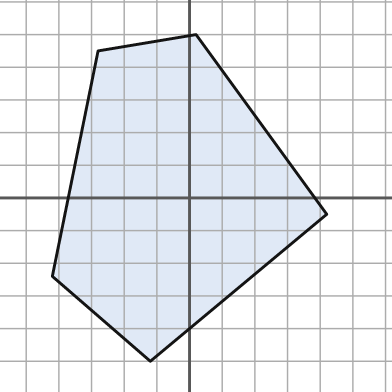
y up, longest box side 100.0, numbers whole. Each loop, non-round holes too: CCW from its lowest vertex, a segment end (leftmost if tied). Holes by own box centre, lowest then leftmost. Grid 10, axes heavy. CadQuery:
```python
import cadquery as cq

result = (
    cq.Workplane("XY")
    .moveTo(-12.0, -50.0)
    .lineTo(42.0, -5.0)
    .lineTo(2.0, 50.0)
    .lineTo(-28.0, 45.0)
    .lineTo(-42.0, -24.0)
    .close()
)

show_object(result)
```